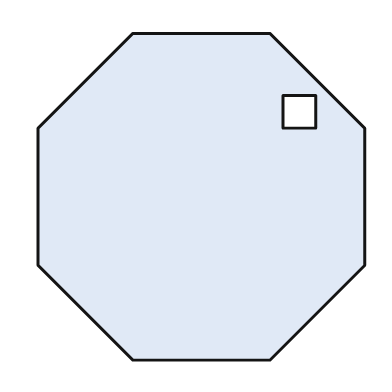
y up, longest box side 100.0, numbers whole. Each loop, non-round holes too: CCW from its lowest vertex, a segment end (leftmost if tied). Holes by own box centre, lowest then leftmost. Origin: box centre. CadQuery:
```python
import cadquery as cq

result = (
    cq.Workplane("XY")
    .moveTo(-21.0, -50.0)
    .lineTo(21.0, -50.0)
    .lineTo(50.0, -21.0)
    .lineTo(50.0, 21.0)
    .lineTo(21.0, 50.0)
    .lineTo(-21.0, 50.0)
    .lineTo(-50.0, 21.0)
    .lineTo(-50.0, -21.0)
    .close()
    .moveTo(25.0, 21.0)
    .lineTo(35.0, 21.0)
    .lineTo(35.0, 31.0)
    .lineTo(25.0, 31.0)
    .close()
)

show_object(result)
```